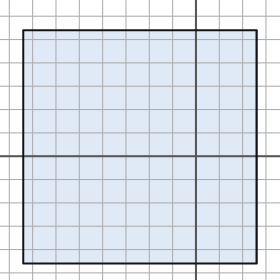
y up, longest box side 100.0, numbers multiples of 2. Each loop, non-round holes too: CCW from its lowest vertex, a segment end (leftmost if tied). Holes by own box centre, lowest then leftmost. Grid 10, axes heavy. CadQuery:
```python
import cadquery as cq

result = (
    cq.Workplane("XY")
    .moveTo(-74.0, -46.0)
    .lineTo(26.0, -46.0)
    .lineTo(26.0, 54.0)
    .lineTo(-74.0, 54.0)
    .close()
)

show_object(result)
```